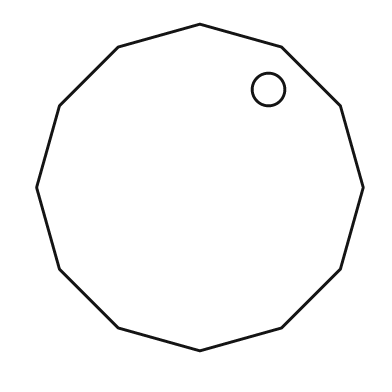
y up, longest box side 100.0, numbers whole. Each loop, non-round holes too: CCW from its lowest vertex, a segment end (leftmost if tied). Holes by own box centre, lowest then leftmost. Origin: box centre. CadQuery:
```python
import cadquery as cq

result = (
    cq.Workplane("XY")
    .moveTo(0.0, -50.0)
    .lineTo(25.0, -43.0)
    .lineTo(43.0, -25.0)
    .lineTo(50.0, 0.0)
    .lineTo(43.0, 25.0)
    .lineTo(25.0, 43.0)
    .lineTo(0.0, 50.0)
    .lineTo(-25.0, 43.0)
    .lineTo(-43.0, 25.0)
    .lineTo(-50.0, 0.0)
    .lineTo(-43.0, -25.0)
    .lineTo(-25.0, -43.0)
    .close()
    .moveTo(21.0, 30.0)
    .circle(5.0)
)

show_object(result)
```